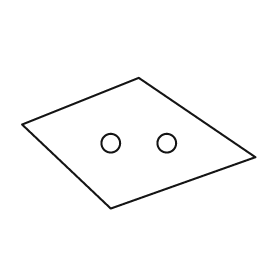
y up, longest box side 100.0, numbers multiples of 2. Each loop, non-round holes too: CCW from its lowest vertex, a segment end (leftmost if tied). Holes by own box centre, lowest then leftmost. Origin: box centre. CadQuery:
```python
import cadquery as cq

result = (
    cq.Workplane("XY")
    .moveTo(-12.0, -28.0)
    .lineTo(50.0, -6.0)
    .lineTo(0.0, 28.0)
    .lineTo(-50.0, 8.0)
    .close()
    .moveTo(-12.0, 0.0)
    .circle(4.0)
    .moveTo(12.0, 0.0)
    .circle(4.0)
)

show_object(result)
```